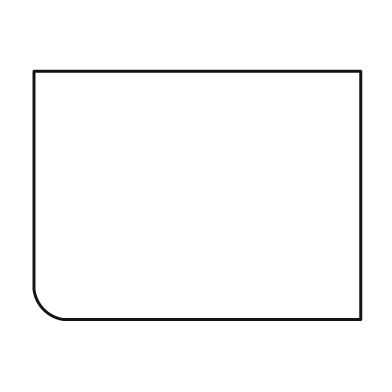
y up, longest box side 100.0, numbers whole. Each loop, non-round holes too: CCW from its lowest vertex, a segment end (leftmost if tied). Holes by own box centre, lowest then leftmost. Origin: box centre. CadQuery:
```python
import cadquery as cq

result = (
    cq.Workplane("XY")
    .moveTo(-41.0, -38.0)
    .lineTo(50.0, -38.0)
    .lineTo(50.0, 38.0)
    .lineTo(-50.0, 38.0)
    .lineTo(-50.0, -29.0)
    .threePointArc((-47.0, -35.0), (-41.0, -38.0))
    .close()
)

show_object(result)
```